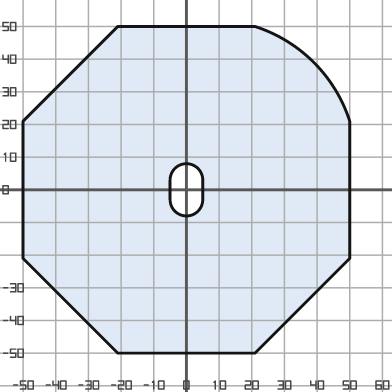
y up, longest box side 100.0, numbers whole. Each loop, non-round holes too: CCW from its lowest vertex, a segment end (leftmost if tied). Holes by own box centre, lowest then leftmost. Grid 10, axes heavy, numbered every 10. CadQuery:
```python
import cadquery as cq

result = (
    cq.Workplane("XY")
    .moveTo(-21.0, -50.0)
    .lineTo(21.0, -50.0)
    .lineTo(50.0, -21.0)
    .lineTo(50.0, 21.0)
    .threePointArc((39.0, 39.0), (21.0, 50.0))
    .lineTo(-21.0, 50.0)
    .lineTo(-50.0, 21.0)
    .lineTo(-50.0, -21.0)
    .close()
    .moveTo(-5.0, -3.0)
    .threePointArc((0.0, -8.0), (5.0, -3.0))
    .lineTo(5.0, 3.0)
    .threePointArc((0.0, 8.0), (-5.0, 3.0))
    .close()
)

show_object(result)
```